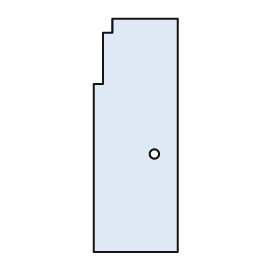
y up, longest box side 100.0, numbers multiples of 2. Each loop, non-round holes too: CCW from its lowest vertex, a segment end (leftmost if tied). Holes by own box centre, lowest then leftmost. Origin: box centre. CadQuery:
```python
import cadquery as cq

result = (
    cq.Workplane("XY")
    .moveTo(-18.0, -50.0)
    .lineTo(18.0, -50.0)
    .lineTo(18.0, 50.0)
    .lineTo(-10.0, 50.0)
    .lineTo(-10.0, 44.0)
    .lineTo(-14.0, 44.0)
    .lineTo(-14.0, 22.0)
    .lineTo(-18.0, 22.0)
    .close()
    .moveTo(8.0, -8.0)
    .circle(2.0)
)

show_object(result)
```